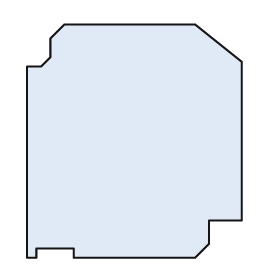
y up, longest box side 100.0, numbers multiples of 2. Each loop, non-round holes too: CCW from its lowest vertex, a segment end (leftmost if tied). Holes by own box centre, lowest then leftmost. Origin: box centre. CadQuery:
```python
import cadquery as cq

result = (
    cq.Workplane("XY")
    .moveTo(-46.0, -50.0)
    .lineTo(-42.0, -50.0)
    .lineTo(-42.0, -46.0)
    .lineTo(-26.0, -46.0)
    .lineTo(-26.0, -50.0)
    .lineTo(26.0, -50.0)
    .lineTo(32.0, -44.0)
    .lineTo(32.0, -34.0)
    .lineTo(46.0, -34.0)
    .lineTo(46.0, 34.0)
    .lineTo(26.0, 50.0)
    .lineTo(-30.0, 50.0)
    .lineTo(-36.0, 44.0)
    .lineTo(-36.0, 36.0)
    .lineTo(-40.0, 32.0)
    .lineTo(-46.0, 32.0)
    .close()
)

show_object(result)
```